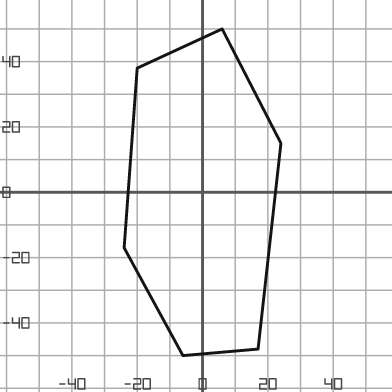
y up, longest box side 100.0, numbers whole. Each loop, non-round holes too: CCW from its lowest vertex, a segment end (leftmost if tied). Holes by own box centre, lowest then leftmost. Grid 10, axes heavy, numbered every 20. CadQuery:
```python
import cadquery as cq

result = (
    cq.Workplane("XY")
    .moveTo(-6.0, -50.0)
    .lineTo(17.0, -48.0)
    .lineTo(24.0, 15.0)
    .lineTo(6.0, 50.0)
    .lineTo(-20.0, 38.0)
    .lineTo(-24.0, -17.0)
    .close()
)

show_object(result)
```